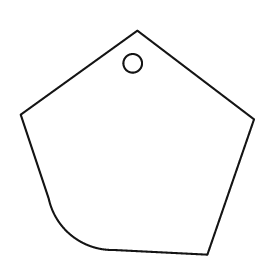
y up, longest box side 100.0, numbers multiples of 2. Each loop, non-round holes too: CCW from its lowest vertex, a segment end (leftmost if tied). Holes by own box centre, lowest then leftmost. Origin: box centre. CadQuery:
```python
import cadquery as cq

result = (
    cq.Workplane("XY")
    .moveTo(30.0, -48.0)
    .lineTo(50.0, 10.0)
    .lineTo(0.0, 48.0)
    .lineTo(-50.0, 12.0)
    .lineTo(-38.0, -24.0)
    .threePointArc((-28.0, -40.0), (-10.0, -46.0))
    .close()
    .moveTo(-2.0, 34.0)
    .circle(4.0)
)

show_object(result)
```